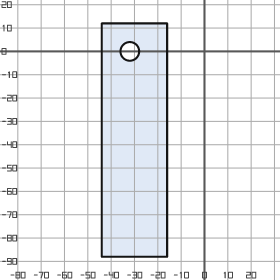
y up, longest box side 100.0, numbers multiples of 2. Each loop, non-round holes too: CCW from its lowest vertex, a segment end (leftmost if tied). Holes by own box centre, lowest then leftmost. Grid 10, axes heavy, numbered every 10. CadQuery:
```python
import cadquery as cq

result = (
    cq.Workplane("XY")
    .moveTo(-44.0, -88.0)
    .lineTo(-16.0, -88.0)
    .lineTo(-16.0, 12.0)
    .lineTo(-44.0, 12.0)
    .close()
    .moveTo(-32.0, 0.0)
    .circle(4.0)
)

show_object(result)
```